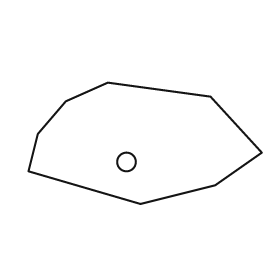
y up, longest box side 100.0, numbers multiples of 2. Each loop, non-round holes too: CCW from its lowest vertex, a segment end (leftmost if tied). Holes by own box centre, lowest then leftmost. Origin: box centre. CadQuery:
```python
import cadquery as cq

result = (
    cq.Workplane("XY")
    .moveTo(-2.0, -26.0)
    .lineTo(30.0, -18.0)
    .lineTo(50.0, -4.0)
    .lineTo(28.0, 20.0)
    .lineTo(-16.0, 26.0)
    .lineTo(-34.0, 18.0)
    .lineTo(-46.0, 4.0)
    .lineTo(-50.0, -12.0)
    .close()
    .moveTo(-8.0, -8.0)
    .circle(4.0)
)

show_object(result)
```